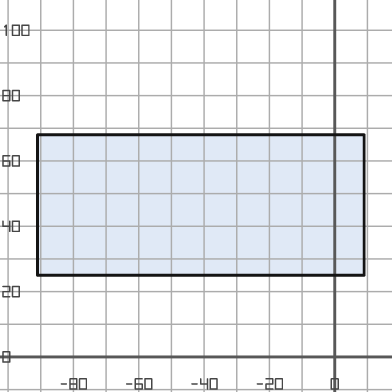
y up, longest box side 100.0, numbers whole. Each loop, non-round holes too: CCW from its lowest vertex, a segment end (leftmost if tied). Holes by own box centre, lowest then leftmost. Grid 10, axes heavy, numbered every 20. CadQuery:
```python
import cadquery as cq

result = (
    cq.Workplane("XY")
    .moveTo(-91.0, 25.0)
    .lineTo(9.0, 25.0)
    .lineTo(9.0, 68.0)
    .lineTo(-91.0, 68.0)
    .close()
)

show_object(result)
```